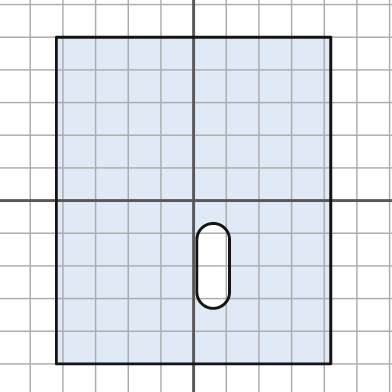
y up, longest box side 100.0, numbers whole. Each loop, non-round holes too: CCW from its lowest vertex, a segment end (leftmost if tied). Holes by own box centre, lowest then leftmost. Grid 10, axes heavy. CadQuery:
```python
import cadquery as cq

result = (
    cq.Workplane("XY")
    .moveTo(-42.0, -50.0)
    .lineTo(42.0, -50.0)
    .lineTo(42.0, 50.0)
    .lineTo(-42.0, 50.0)
    .close()
    .moveTo(1.0, -28.0)
    .threePointArc((6.0, -33.0), (11.0, -28.0))
    .lineTo(11.0, -12.0)
    .threePointArc((6.0, -7.0), (1.0, -12.0))
    .close()
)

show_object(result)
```